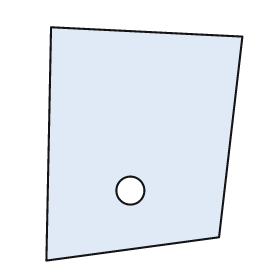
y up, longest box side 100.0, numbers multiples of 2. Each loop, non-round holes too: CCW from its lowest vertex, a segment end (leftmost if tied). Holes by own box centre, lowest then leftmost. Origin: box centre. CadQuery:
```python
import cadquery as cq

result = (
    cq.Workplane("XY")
    .moveTo(-42.0, -50.0)
    .lineTo(32.0, -40.0)
    .lineTo(42.0, 46.0)
    .lineTo(-40.0, 50.0)
    .close()
    .moveTo(-6.0, -20.0)
    .circle(6.0)
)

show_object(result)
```